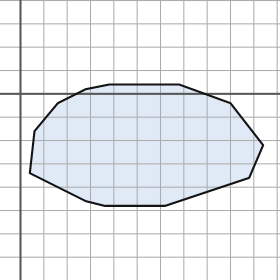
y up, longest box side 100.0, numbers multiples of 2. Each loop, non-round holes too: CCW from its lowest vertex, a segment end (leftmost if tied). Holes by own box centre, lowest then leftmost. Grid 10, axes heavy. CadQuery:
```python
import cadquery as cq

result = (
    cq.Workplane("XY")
    .moveTo(36.0, -48.0)
    .lineTo(62.0, -48.0)
    .lineTo(98.0, -36.0)
    .lineTo(104.0, -22.0)
    .lineTo(90.0, -4.0)
    .lineTo(68.0, 4.0)
    .lineTo(38.0, 4.0)
    .lineTo(28.0, 2.0)
    .lineTo(16.0, -4.0)
    .lineTo(6.0, -16.0)
    .lineTo(4.0, -34.0)
    .lineTo(28.0, -46.0)
    .close()
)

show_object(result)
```